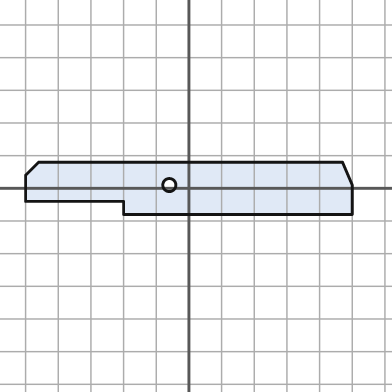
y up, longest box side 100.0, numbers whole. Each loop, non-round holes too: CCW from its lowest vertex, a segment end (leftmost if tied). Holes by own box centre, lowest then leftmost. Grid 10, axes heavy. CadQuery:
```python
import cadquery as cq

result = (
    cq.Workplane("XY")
    .moveTo(-20.0, -8.0)
    .lineTo(50.0, -8.0)
    .lineTo(50.0, 1.0)
    .lineTo(47.0, 8.0)
    .lineTo(-46.0, 8.0)
    .lineTo(-50.0, 4.0)
    .lineTo(-50.0, -4.0)
    .lineTo(-20.0, -4.0)
    .close()
    .moveTo(-6.0, 1.0)
    .circle(2.0)
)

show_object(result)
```